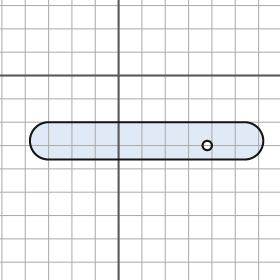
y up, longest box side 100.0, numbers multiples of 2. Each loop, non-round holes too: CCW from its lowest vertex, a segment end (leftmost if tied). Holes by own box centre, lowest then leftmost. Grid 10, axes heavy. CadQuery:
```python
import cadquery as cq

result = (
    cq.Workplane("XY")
    .moveTo(-30.0, -36.0)
    .lineTo(54.0, -36.0)
    .threePointArc((62.0, -28.0), (54.0, -20.0))
    .lineTo(-30.0, -20.0)
    .threePointArc((-38.0, -28.0), (-30.0, -36.0))
    .close()
    .moveTo(38.0, -30.0)
    .circle(2.0)
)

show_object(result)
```